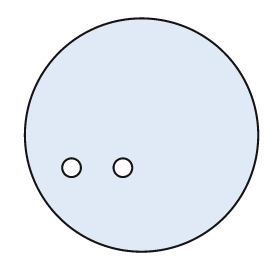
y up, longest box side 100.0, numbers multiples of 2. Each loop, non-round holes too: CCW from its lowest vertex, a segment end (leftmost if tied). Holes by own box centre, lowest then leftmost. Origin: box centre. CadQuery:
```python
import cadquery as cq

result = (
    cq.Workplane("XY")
    .moveTo(0.0, 0.0)
    .circle(50.0)
    .moveTo(-30.0, -14.0)
    .circle(4.0)
    .moveTo(-8.0, -14.0)
    .circle(4.0)
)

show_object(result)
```